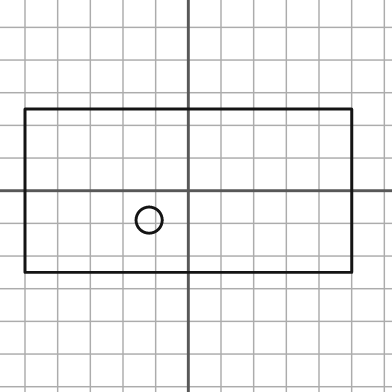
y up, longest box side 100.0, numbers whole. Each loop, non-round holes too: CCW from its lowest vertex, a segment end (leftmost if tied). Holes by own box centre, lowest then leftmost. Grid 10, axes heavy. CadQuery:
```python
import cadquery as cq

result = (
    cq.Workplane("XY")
    .moveTo(-50.0, -25.0)
    .lineTo(50.0, -25.0)
    .lineTo(50.0, 25.0)
    .lineTo(-50.0, 25.0)
    .close()
    .moveTo(-12.0, -9.0)
    .circle(4.0)
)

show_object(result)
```